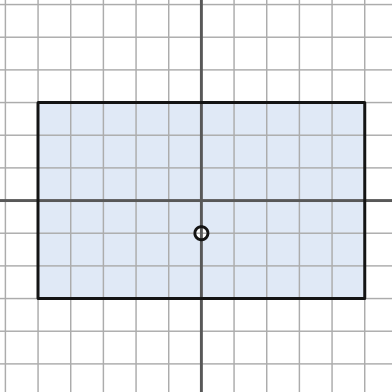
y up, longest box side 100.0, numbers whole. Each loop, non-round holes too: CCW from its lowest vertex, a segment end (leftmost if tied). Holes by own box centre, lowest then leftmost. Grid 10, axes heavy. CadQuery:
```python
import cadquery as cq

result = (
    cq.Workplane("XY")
    .moveTo(-50.0, -30.0)
    .lineTo(50.0, -30.0)
    .lineTo(50.0, 30.0)
    .lineTo(-50.0, 30.0)
    .close()
    .moveTo(0.0, -10.0)
    .circle(2.0)
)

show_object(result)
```